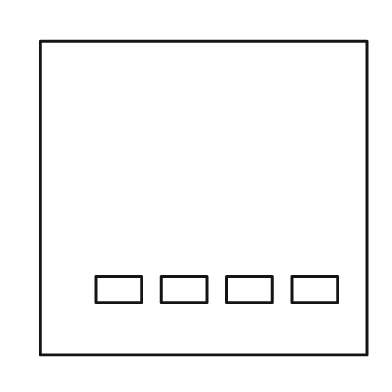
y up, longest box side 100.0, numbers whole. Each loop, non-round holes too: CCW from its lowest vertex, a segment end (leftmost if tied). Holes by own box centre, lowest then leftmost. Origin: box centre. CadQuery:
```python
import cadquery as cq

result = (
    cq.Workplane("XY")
    .moveTo(-50.0, -48.0)
    .lineTo(50.0, -48.0)
    .lineTo(50.0, 48.0)
    .lineTo(-50.0, 48.0)
    .close()
    .moveTo(-33.0, -32.0)
    .lineTo(-19.0, -32.0)
    .lineTo(-19.0, -24.0)
    .lineTo(-33.0, -24.0)
    .close()
    .moveTo(-13.0, -32.0)
    .lineTo(1.0, -32.0)
    .lineTo(1.0, -24.0)
    .lineTo(-13.0, -24.0)
    .close()
    .moveTo(7.0, -32.0)
    .lineTo(21.0, -32.0)
    .lineTo(21.0, -24.0)
    .lineTo(7.0, -24.0)
    .close()
    .moveTo(27.0, -32.0)
    .lineTo(41.0, -32.0)
    .lineTo(41.0, -24.0)
    .lineTo(27.0, -24.0)
    .close()
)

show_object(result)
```